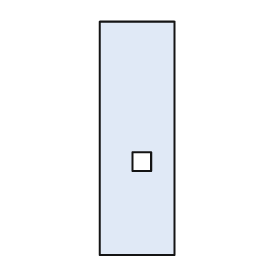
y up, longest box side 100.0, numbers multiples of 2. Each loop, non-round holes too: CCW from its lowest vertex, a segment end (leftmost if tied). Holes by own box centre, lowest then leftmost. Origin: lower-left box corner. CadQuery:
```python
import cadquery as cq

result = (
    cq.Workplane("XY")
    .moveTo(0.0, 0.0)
    .lineTo(32.0, 0.0)
    .lineTo(32.0, 100.0)
    .lineTo(0.0, 100.0)
    .close()
    .moveTo(14.0, 36.0)
    .lineTo(22.0, 36.0)
    .lineTo(22.0, 44.0)
    .lineTo(14.0, 44.0)
    .close()
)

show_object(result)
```